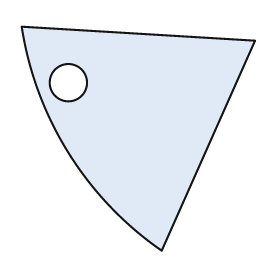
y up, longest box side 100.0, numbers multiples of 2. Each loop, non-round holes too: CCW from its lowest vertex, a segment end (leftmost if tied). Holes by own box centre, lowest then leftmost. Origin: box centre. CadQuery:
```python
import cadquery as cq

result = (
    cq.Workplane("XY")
    .moveTo(10.0, -48.0)
    .lineTo(50.0, 42.0)
    .lineTo(-50.0, 48.0)
    .threePointArc((-30.0, -6.0), (10.0, -48.0))
    .close()
    .moveTo(-30.0, 24.0)
    .circle(8.0)
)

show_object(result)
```